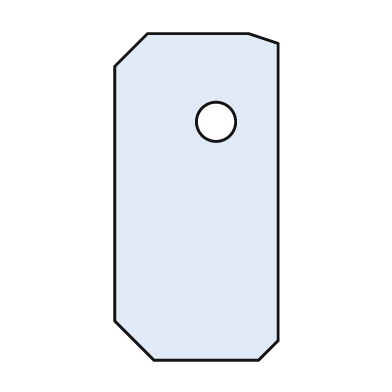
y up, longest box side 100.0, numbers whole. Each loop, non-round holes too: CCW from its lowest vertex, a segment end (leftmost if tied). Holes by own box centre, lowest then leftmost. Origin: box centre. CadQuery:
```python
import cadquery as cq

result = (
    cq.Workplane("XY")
    .moveTo(-13.0, -50.0)
    .lineTo(19.0, -50.0)
    .lineTo(25.0, -44.0)
    .lineTo(25.0, 47.0)
    .lineTo(16.0, 50.0)
    .lineTo(-15.0, 50.0)
    .lineTo(-25.0, 40.0)
    .lineTo(-25.0, -38.0)
    .close()
    .moveTo(6.0, 23.0)
    .circle(6.0)
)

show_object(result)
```